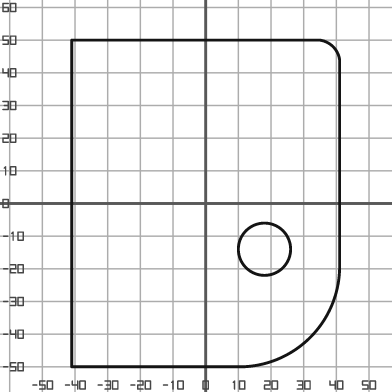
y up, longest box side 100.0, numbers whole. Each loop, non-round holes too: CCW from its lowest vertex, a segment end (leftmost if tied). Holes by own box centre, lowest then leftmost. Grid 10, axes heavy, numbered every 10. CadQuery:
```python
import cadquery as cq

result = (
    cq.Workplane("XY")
    .moveTo(-41.0, -50.0)
    .lineTo(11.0, -50.0)
    .threePointArc((32.0, -41.0), (41.0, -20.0))
    .lineTo(41.0, 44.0)
    .threePointArc((39.0, 48.0), (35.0, 50.0))
    .lineTo(-41.0, 50.0)
    .close()
    .moveTo(18.0, -14.0)
    .circle(8.0)
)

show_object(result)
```